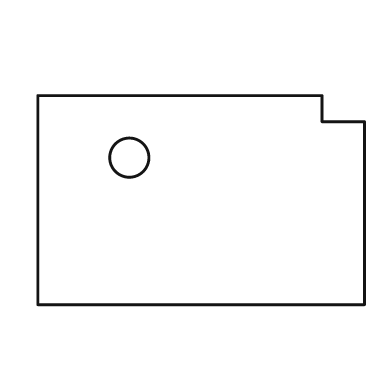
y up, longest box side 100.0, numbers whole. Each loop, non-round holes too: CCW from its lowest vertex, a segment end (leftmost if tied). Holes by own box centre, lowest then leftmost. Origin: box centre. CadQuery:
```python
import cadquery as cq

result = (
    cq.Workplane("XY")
    .moveTo(-50.0, -32.0)
    .lineTo(50.0, -32.0)
    .lineTo(50.0, 24.0)
    .lineTo(37.0, 24.0)
    .lineTo(37.0, 32.0)
    .lineTo(-50.0, 32.0)
    .close()
    .moveTo(-22.0, 13.0)
    .circle(6.0)
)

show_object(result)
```